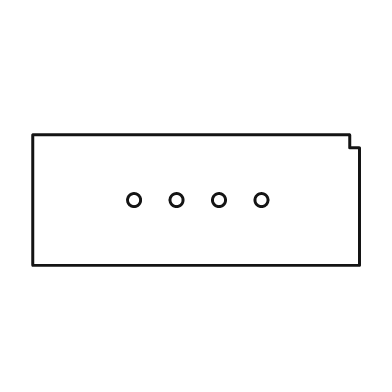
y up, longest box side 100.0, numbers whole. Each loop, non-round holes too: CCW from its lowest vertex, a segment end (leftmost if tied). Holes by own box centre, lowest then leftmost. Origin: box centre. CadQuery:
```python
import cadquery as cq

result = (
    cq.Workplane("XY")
    .moveTo(-50.0, -20.0)
    .lineTo(50.0, -20.0)
    .lineTo(50.0, 16.0)
    .lineTo(47.0, 16.0)
    .lineTo(47.0, 20.0)
    .lineTo(-50.0, 20.0)
    .close()
    .moveTo(-19.0, 0.0)
    .circle(2.0)
    .moveTo(-6.0, 0.0)
    .circle(2.0)
    .moveTo(7.0, 0.0)
    .circle(2.0)
    .moveTo(20.0, 0.0)
    .circle(2.0)
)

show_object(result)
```